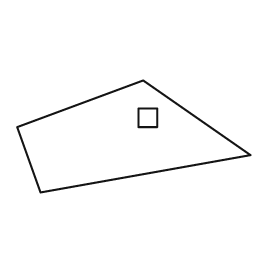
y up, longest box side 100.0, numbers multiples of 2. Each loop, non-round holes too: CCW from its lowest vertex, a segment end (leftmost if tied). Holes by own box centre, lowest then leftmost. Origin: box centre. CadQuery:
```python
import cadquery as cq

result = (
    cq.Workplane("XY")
    .moveTo(-40.0, -24.0)
    .lineTo(50.0, -8.0)
    .lineTo(4.0, 24.0)
    .lineTo(-50.0, 4.0)
    .close()
    .moveTo(2.0, 4.0)
    .lineTo(10.0, 4.0)
    .lineTo(10.0, 12.0)
    .lineTo(2.0, 12.0)
    .close()
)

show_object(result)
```